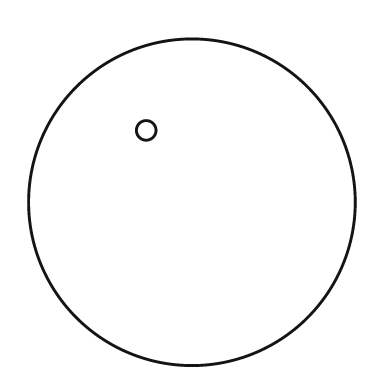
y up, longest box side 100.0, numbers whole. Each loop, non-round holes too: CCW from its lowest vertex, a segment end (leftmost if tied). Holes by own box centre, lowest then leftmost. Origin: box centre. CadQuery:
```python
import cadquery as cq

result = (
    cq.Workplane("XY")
    .moveTo(0.0, 0.0)
    .circle(50.0)
    .moveTo(-14.0, 22.0)
    .circle(3.0)
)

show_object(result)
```